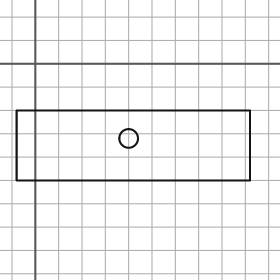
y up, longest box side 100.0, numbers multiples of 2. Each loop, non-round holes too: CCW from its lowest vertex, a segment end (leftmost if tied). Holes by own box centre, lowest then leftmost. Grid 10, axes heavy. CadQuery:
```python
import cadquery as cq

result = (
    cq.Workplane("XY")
    .moveTo(-8.0, -50.0)
    .lineTo(92.0, -50.0)
    .lineTo(92.0, -20.0)
    .lineTo(-8.0, -20.0)
    .close()
    .moveTo(40.0, -32.0)
    .circle(4.0)
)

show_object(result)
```